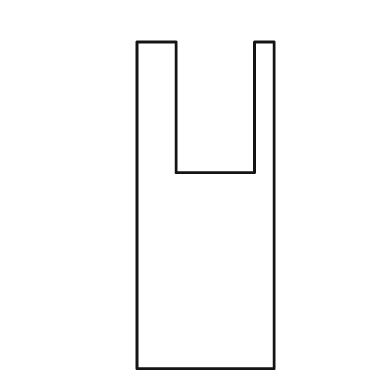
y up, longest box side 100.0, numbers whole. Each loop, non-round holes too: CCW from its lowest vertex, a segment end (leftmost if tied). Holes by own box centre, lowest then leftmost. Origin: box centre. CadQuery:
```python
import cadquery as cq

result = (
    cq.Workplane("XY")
    .moveTo(-21.0, -50.0)
    .lineTo(21.0, -50.0)
    .lineTo(21.0, 50.0)
    .lineTo(15.0, 50.0)
    .lineTo(15.0, 10.0)
    .lineTo(-9.0, 10.0)
    .lineTo(-9.0, 50.0)
    .lineTo(-21.0, 50.0)
    .close()
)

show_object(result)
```